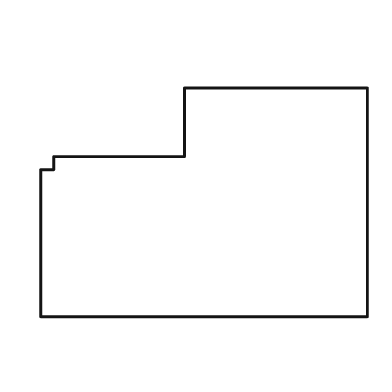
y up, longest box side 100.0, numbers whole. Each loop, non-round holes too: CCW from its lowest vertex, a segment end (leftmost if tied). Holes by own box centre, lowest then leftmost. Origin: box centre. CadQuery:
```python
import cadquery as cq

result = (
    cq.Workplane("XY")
    .moveTo(-50.0, -35.0)
    .lineTo(50.0, -35.0)
    .lineTo(50.0, 35.0)
    .lineTo(-6.0, 35.0)
    .lineTo(-6.0, 14.0)
    .lineTo(-46.0, 14.0)
    .lineTo(-46.0, 10.0)
    .lineTo(-50.0, 10.0)
    .close()
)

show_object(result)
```